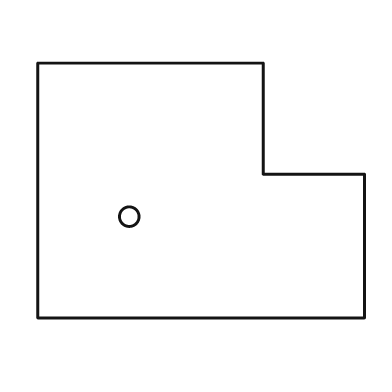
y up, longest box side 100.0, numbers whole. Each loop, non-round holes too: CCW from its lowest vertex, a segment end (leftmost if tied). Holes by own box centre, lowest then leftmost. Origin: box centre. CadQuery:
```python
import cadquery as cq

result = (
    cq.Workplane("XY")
    .moveTo(-50.0, -39.0)
    .lineTo(50.0, -39.0)
    .lineTo(50.0, 5.0)
    .lineTo(19.0, 5.0)
    .lineTo(19.0, 39.0)
    .lineTo(-50.0, 39.0)
    .close()
    .moveTo(-22.0, -8.0)
    .circle(3.0)
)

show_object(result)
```